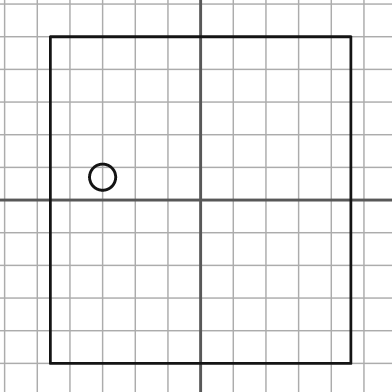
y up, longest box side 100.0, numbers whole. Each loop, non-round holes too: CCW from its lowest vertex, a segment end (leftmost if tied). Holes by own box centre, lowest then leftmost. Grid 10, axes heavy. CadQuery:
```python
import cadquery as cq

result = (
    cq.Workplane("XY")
    .moveTo(-46.0, -50.0)
    .lineTo(46.0, -50.0)
    .lineTo(46.0, 50.0)
    .lineTo(-46.0, 50.0)
    .close()
    .moveTo(-30.0, 7.0)
    .circle(4.0)
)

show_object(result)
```